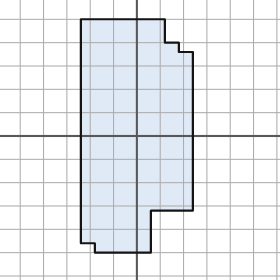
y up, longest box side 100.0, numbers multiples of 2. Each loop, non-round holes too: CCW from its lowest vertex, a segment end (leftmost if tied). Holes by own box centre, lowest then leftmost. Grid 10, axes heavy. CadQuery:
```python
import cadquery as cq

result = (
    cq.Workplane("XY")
    .moveTo(-18.0, -50.0)
    .lineTo(6.0, -50.0)
    .lineTo(6.0, -32.0)
    .lineTo(24.0, -32.0)
    .lineTo(24.0, 36.0)
    .lineTo(18.0, 36.0)
    .lineTo(18.0, 40.0)
    .lineTo(12.0, 40.0)
    .lineTo(12.0, 50.0)
    .lineTo(-24.0, 50.0)
    .lineTo(-24.0, -46.0)
    .lineTo(-18.0, -46.0)
    .close()
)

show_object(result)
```